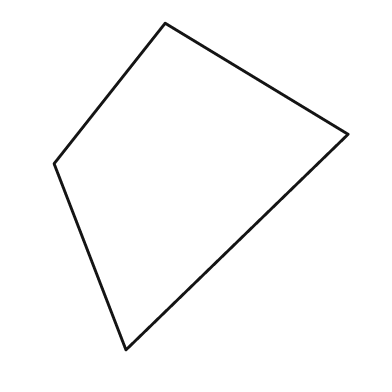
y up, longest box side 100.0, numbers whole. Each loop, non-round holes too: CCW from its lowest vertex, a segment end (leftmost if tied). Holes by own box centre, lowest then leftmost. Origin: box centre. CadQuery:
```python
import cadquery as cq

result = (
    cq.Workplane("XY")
    .moveTo(-23.0, -50.0)
    .lineTo(45.0, 16.0)
    .lineTo(-11.0, 50.0)
    .lineTo(-45.0, 7.0)
    .close()
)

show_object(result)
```